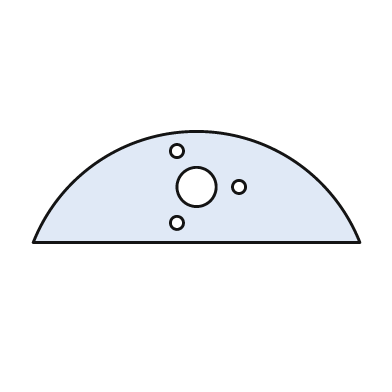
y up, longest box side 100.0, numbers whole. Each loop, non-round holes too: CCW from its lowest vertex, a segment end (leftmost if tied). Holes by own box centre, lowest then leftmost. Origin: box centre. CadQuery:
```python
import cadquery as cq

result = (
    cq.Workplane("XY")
    .moveTo(-50.0, -17.0)
    .lineTo(50.0, -17.0)
    .threePointArc((0.0, 17.0), (-50.0, -17.0))
    .close()
    .moveTo(-6.0, -11.0)
    .circle(2.0)
    .moveTo(0.0, 0.0)
    .circle(6.0)
    .moveTo(13.0, 0.0)
    .circle(2.0)
    .moveTo(-6.0, 11.0)
    .circle(2.0)
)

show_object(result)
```